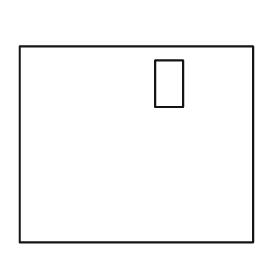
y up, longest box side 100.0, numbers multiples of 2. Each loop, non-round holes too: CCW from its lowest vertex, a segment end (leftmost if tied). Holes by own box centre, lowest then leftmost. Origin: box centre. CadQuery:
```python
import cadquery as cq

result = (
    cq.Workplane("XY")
    .moveTo(-50.0, -42.0)
    .lineTo(50.0, -42.0)
    .lineTo(50.0, 42.0)
    .lineTo(-50.0, 42.0)
    .close()
    .moveTo(8.0, 16.0)
    .lineTo(20.0, 16.0)
    .lineTo(20.0, 36.0)
    .lineTo(8.0, 36.0)
    .close()
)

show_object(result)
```